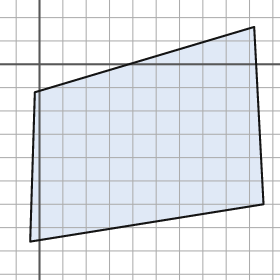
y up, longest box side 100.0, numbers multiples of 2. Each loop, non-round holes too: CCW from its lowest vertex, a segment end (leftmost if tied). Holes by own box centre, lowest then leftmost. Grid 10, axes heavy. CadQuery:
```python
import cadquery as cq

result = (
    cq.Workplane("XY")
    .moveTo(-4.0, -76.0)
    .lineTo(96.0, -60.0)
    .lineTo(92.0, 16.0)
    .lineTo(-2.0, -12.0)
    .close()
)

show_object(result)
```